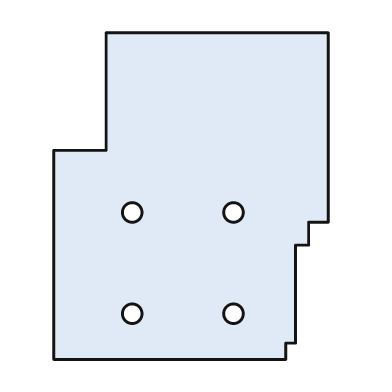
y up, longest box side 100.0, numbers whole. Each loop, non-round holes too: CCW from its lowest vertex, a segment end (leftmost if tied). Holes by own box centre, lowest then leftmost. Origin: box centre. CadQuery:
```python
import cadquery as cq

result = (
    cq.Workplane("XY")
    .moveTo(-42.0, -50.0)
    .lineTo(29.0, -50.0)
    .lineTo(29.0, -45.0)
    .lineTo(32.0, -45.0)
    .lineTo(32.0, -15.0)
    .lineTo(36.0, -15.0)
    .lineTo(36.0, -8.0)
    .lineTo(42.0, -8.0)
    .lineTo(42.0, 50.0)
    .lineTo(-26.0, 50.0)
    .lineTo(-26.0, 14.0)
    .lineTo(-42.0, 14.0)
    .close()
    .moveTo(-18.0, -36.0)
    .circle(3.0)
    .moveTo(13.0, -36.0)
    .circle(3.0)
    .moveTo(-18.0, -5.0)
    .circle(3.0)
    .moveTo(13.0, -5.0)
    .circle(3.0)
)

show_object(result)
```